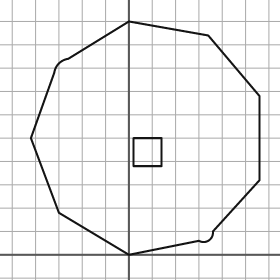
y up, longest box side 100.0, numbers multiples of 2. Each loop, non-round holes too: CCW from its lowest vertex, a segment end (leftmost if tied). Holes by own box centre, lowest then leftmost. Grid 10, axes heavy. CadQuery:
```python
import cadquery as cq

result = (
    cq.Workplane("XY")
    .moveTo(0.0, 0.0)
    .lineTo(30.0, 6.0)
    .threePointArc((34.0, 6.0), (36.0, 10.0))
    .lineTo(56.0, 32.0)
    .lineTo(56.0, 68.0)
    .lineTo(34.0, 94.0)
    .lineTo(0.0, 100.0)
    .lineTo(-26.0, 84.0)
    .threePointArc((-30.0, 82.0), (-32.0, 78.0))
    .lineTo(-42.0, 50.0)
    .lineTo(-30.0, 18.0)
    .close()
    .moveTo(2.0, 38.0)
    .lineTo(14.0, 38.0)
    .lineTo(14.0, 50.0)
    .lineTo(2.0, 50.0)
    .close()
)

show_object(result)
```